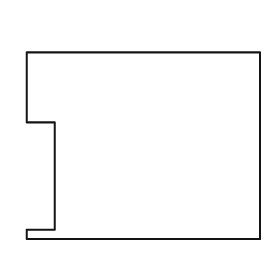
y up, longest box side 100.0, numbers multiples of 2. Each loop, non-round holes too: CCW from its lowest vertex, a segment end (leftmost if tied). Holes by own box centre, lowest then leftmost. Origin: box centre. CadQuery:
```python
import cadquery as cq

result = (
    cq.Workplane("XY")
    .moveTo(-50.0, -40.0)
    .lineTo(50.0, -40.0)
    .lineTo(50.0, 40.0)
    .lineTo(-50.0, 40.0)
    .lineTo(-50.0, 10.0)
    .lineTo(-38.0, 10.0)
    .lineTo(-38.0, -36.0)
    .lineTo(-50.0, -36.0)
    .close()
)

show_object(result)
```